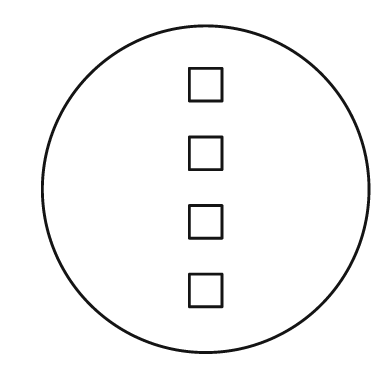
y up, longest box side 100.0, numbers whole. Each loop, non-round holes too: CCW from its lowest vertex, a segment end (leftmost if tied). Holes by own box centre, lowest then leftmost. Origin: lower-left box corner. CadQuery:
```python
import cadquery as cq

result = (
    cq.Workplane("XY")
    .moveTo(50.0, 50.0)
    .circle(50.0)
    .moveTo(45.0, 14.0)
    .lineTo(55.0, 14.0)
    .lineTo(55.0, 24.0)
    .lineTo(45.0, 24.0)
    .close()
    .moveTo(45.0, 35.0)
    .lineTo(55.0, 35.0)
    .lineTo(55.0, 45.0)
    .lineTo(45.0, 45.0)
    .close()
    .moveTo(45.0, 56.0)
    .lineTo(55.0, 56.0)
    .lineTo(55.0, 66.0)
    .lineTo(45.0, 66.0)
    .close()
    .moveTo(45.0, 77.0)
    .lineTo(55.0, 77.0)
    .lineTo(55.0, 87.0)
    .lineTo(45.0, 87.0)
    .close()
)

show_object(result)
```